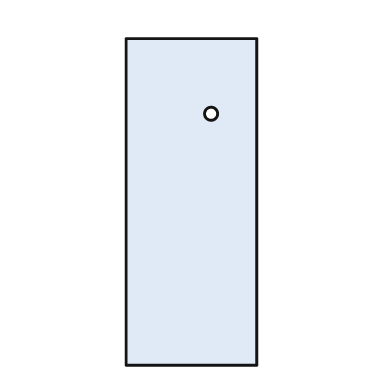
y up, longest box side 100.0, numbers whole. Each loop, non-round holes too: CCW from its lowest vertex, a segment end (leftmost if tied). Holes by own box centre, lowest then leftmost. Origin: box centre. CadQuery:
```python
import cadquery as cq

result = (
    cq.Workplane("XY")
    .moveTo(-20.0, -50.0)
    .lineTo(20.0, -50.0)
    .lineTo(20.0, 50.0)
    .lineTo(-20.0, 50.0)
    .close()
    .moveTo(6.0, 27.0)
    .circle(2.0)
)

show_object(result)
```